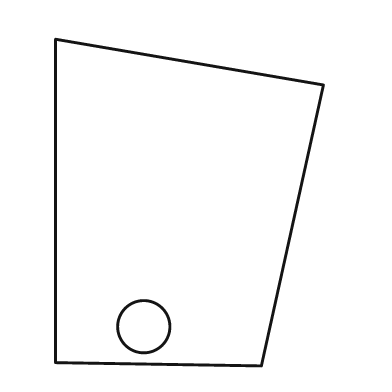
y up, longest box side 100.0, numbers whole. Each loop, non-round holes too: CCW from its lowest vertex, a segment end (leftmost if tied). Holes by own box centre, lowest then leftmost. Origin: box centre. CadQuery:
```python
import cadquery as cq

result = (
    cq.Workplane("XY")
    .moveTo(22.0, -50.0)
    .lineTo(41.0, 36.0)
    .lineTo(-41.0, 50.0)
    .lineTo(-41.0, -49.0)
    .close()
    .moveTo(-14.0, -38.0)
    .circle(8.0)
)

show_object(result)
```